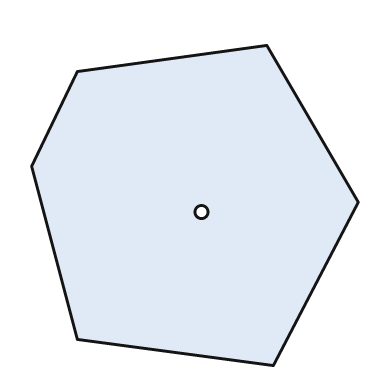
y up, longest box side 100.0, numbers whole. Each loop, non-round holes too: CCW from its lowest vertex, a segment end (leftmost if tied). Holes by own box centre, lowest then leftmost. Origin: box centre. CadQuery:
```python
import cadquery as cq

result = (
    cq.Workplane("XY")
    .moveTo(24.0, -49.0)
    .lineTo(50.0, 1.0)
    .lineTo(22.0, 49.0)
    .lineTo(-36.0, 41.0)
    .lineTo(-50.0, 12.0)
    .lineTo(-36.0, -41.0)
    .close()
    .moveTo(2.0, -2.0)
    .circle(2.0)
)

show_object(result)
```